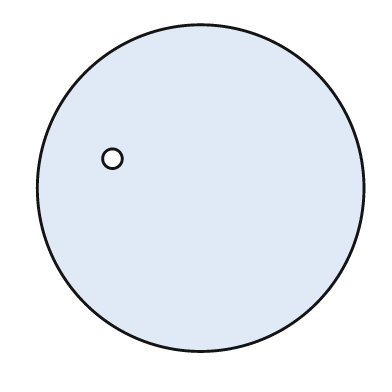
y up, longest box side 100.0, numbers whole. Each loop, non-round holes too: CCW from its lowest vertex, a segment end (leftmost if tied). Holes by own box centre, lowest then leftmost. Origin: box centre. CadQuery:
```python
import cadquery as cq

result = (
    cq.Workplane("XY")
    .moveTo(0.0, 0.0)
    .circle(50.0)
    .moveTo(-27.0, 9.0)
    .circle(3.0)
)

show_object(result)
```